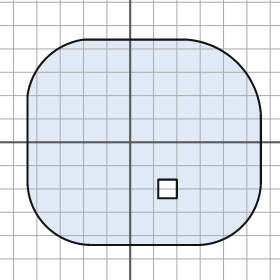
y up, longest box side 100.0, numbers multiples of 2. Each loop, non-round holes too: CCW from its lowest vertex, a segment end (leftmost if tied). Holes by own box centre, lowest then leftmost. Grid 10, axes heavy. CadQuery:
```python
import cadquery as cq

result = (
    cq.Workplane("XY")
    .moveTo(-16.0, -44.0)
    .lineTo(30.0, -44.0)
    .threePointArc((48.0, -36.0), (56.0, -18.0))
    .lineTo(56.0, 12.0)
    .threePointArc((46.0, 34.0), (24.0, 44.0))
    .lineTo(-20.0, 44.0)
    .threePointArc((-36.0, 36.0), (-44.0, 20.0))
    .lineTo(-44.0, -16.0)
    .threePointArc((-36.0, -36.0), (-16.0, -44.0))
    .close()
    .moveTo(12.0, -24.0)
    .lineTo(20.0, -24.0)
    .lineTo(20.0, -16.0)
    .lineTo(12.0, -16.0)
    .close()
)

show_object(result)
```